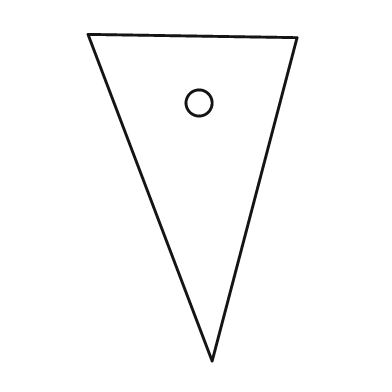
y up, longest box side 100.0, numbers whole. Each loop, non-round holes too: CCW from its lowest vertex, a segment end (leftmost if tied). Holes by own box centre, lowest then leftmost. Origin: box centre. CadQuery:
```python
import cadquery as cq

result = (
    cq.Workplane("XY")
    .moveTo(6.0, -50.0)
    .lineTo(32.0, 49.0)
    .lineTo(-32.0, 50.0)
    .close()
    .moveTo(2.0, 29.0)
    .circle(4.0)
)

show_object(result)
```